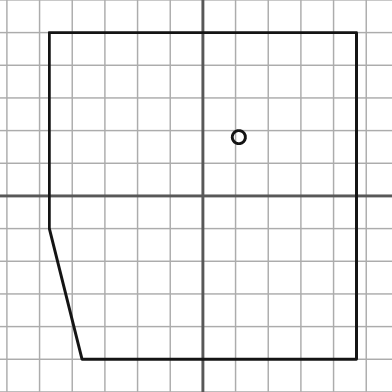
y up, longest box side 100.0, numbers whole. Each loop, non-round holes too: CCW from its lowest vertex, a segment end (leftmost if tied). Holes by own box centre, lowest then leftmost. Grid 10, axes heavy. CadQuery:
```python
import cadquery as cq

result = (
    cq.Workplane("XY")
    .moveTo(-37.0, -50.0)
    .lineTo(47.0, -50.0)
    .lineTo(47.0, 50.0)
    .lineTo(-47.0, 50.0)
    .lineTo(-47.0, -10.0)
    .close()
    .moveTo(11.0, 18.0)
    .circle(2.0)
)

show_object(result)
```